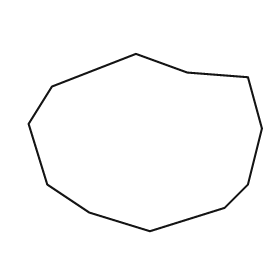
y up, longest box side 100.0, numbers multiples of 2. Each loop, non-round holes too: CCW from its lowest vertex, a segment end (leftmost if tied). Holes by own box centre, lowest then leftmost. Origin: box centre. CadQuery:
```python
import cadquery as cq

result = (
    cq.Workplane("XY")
    .moveTo(2.0, -38.0)
    .lineTo(34.0, -28.0)
    .lineTo(44.0, -18.0)
    .lineTo(50.0, 6.0)
    .lineTo(44.0, 28.0)
    .lineTo(18.0, 30.0)
    .lineTo(-4.0, 38.0)
    .lineTo(-40.0, 24.0)
    .lineTo(-50.0, 8.0)
    .lineTo(-42.0, -18.0)
    .lineTo(-24.0, -30.0)
    .close()
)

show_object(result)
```